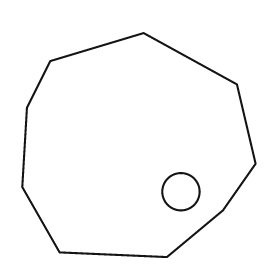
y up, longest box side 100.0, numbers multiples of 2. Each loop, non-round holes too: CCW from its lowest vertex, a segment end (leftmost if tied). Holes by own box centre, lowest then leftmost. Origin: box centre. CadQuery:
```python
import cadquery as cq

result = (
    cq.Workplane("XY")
    .moveTo(12.0, -48.0)
    .lineTo(36.0, -28.0)
    .lineTo(50.0, -8.0)
    .lineTo(42.0, 26.0)
    .lineTo(2.0, 48.0)
    .lineTo(-38.0, 36.0)
    .lineTo(-48.0, 16.0)
    .lineTo(-50.0, -18.0)
    .lineTo(-34.0, -46.0)
    .close()
    .moveTo(18.0, -20.0)
    .circle(8.0)
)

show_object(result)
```